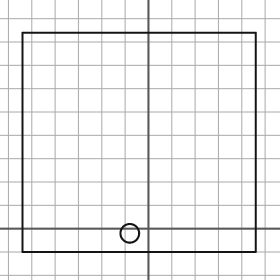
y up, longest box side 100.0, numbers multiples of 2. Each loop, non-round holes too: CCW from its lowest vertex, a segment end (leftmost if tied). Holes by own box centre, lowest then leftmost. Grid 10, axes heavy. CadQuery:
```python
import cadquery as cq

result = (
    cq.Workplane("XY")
    .moveTo(-54.0, -10.0)
    .lineTo(46.0, -10.0)
    .lineTo(46.0, 84.0)
    .lineTo(-54.0, 84.0)
    .close()
    .moveTo(-8.0, -2.0)
    .circle(4.0)
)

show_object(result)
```